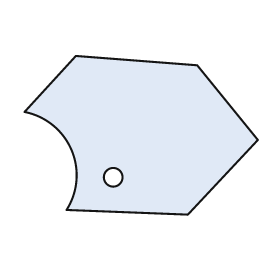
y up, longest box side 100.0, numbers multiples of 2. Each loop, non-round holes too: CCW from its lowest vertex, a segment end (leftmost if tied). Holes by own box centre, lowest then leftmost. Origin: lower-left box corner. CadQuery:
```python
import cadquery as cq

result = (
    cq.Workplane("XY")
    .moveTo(70.0, 0.0)
    .lineTo(100.0, 32.0)
    .lineTo(74.0, 64.0)
    .lineTo(22.0, 68.0)
    .lineTo(0.0, 44.0)
    .threePointArc((20.0, 28.0), (18.0, 2.0))
    .close()
    .moveTo(38.0, 16.0)
    .circle(4.0)
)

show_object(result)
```